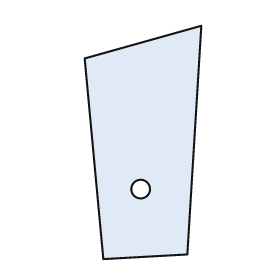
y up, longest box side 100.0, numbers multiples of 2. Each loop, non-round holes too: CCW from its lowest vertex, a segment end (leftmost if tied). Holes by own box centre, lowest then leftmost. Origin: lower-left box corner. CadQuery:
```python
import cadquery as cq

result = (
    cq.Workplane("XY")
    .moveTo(8.0, 0.0)
    .lineTo(44.0, 2.0)
    .lineTo(50.0, 100.0)
    .lineTo(0.0, 86.0)
    .close()
    .moveTo(24.0, 30.0)
    .circle(4.0)
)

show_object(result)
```